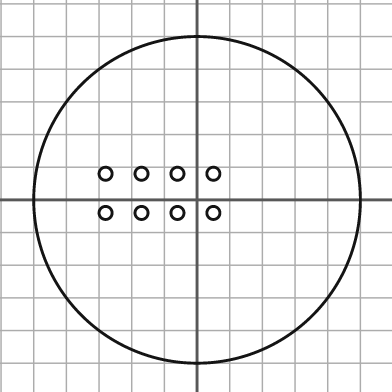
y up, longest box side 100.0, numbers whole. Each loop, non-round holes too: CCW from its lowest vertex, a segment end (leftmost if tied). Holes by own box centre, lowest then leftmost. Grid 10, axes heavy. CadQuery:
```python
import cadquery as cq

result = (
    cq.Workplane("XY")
    .moveTo(0.0, 0.0)
    .circle(50.0)
    .moveTo(-28.0, -4.0)
    .circle(2.0)
    .moveTo(-17.0, -4.0)
    .circle(2.0)
    .moveTo(-6.0, -4.0)
    .circle(2.0)
    .moveTo(5.0, -4.0)
    .circle(2.0)
    .moveTo(-28.0, 8.0)
    .circle(2.0)
    .moveTo(-17.0, 8.0)
    .circle(2.0)
    .moveTo(-6.0, 8.0)
    .circle(2.0)
    .moveTo(5.0, 8.0)
    .circle(2.0)
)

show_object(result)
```